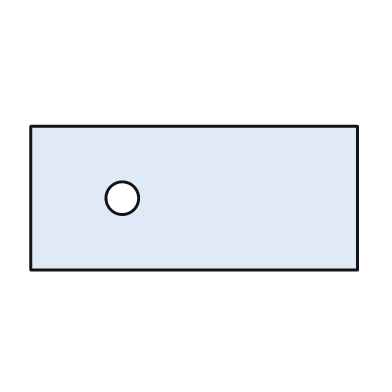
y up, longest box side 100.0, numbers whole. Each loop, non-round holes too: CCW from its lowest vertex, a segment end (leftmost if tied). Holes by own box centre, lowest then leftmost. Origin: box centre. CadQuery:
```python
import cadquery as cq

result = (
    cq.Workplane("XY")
    .moveTo(-50.0, -22.0)
    .lineTo(50.0, -22.0)
    .lineTo(50.0, 22.0)
    .lineTo(-50.0, 22.0)
    .close()
    .moveTo(-22.0, 0.0)
    .circle(5.0)
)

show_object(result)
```